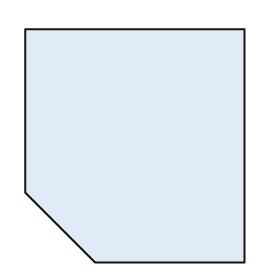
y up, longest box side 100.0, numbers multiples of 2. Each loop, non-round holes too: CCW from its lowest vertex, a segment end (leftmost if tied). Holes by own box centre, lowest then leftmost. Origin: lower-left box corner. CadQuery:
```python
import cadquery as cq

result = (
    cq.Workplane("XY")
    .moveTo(30.0, 0.0)
    .lineTo(94.0, 0.0)
    .lineTo(94.0, 100.0)
    .lineTo(0.0, 100.0)
    .lineTo(0.0, 30.0)
    .close()
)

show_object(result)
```